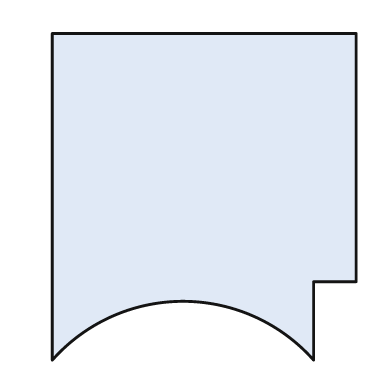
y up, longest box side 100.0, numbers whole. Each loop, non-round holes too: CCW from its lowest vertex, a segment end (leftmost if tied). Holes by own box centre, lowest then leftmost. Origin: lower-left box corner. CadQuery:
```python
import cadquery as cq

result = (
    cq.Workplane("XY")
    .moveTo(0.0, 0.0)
    .threePointArc((40.0, 18.0), (80.0, 0.0))
    .lineTo(80.0, 24.0)
    .lineTo(93.0, 24.0)
    .lineTo(93.0, 100.0)
    .lineTo(0.0, 100.0)
    .close()
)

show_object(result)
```